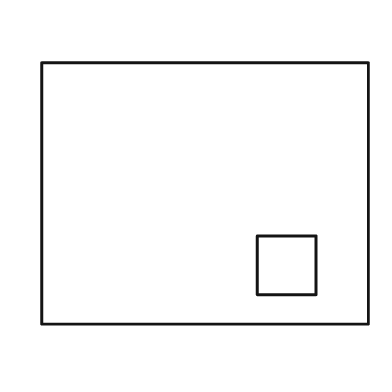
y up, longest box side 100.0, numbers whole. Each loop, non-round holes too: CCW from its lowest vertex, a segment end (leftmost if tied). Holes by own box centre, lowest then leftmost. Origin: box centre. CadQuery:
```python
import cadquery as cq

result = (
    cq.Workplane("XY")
    .moveTo(-50.0, -40.0)
    .lineTo(50.0, -40.0)
    .lineTo(50.0, 40.0)
    .lineTo(-50.0, 40.0)
    .close()
    .moveTo(16.0, -31.0)
    .lineTo(34.0, -31.0)
    .lineTo(34.0, -13.0)
    .lineTo(16.0, -13.0)
    .close()
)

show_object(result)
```